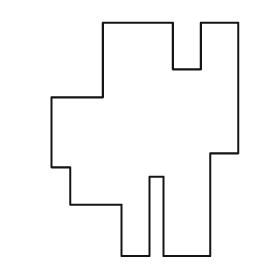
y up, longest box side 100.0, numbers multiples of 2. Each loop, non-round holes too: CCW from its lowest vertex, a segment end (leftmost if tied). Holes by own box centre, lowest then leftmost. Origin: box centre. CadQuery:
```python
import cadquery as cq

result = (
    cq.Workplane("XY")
    .moveTo(-10.0, -50.0)
    .lineTo(2.0, -50.0)
    .lineTo(2.0, -16.0)
    .lineTo(8.0, -16.0)
    .lineTo(8.0, -50.0)
    .lineTo(28.0, -50.0)
    .lineTo(28.0, -6.0)
    .lineTo(40.0, -6.0)
    .lineTo(40.0, 50.0)
    .lineTo(24.0, 50.0)
    .lineTo(24.0, 30.0)
    .lineTo(12.0, 30.0)
    .lineTo(12.0, 50.0)
    .lineTo(-18.0, 50.0)
    .lineTo(-18.0, 18.0)
    .lineTo(-40.0, 18.0)
    .lineTo(-40.0, -12.0)
    .lineTo(-32.0, -12.0)
    .lineTo(-32.0, -28.0)
    .lineTo(-10.0, -28.0)
    .close()
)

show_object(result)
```